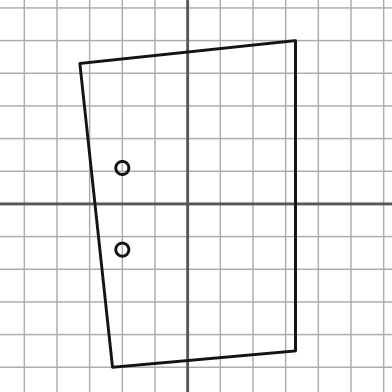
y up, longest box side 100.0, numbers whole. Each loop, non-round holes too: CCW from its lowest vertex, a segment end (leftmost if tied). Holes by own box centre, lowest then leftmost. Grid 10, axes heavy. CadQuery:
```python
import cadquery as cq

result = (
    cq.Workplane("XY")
    .moveTo(-23.0, -50.0)
    .lineTo(33.0, -45.0)
    .lineTo(33.0, 50.0)
    .lineTo(-33.0, 43.0)
    .close()
    .moveTo(-20.0, -14.0)
    .circle(2.0)
    .moveTo(-20.0, 11.0)
    .circle(2.0)
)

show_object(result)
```